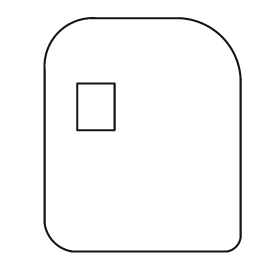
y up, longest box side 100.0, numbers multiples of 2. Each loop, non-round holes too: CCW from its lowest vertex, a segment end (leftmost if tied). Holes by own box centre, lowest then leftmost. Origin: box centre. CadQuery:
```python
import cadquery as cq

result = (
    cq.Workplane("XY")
    .moveTo(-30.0, -50.0)
    .lineTo(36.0, -50.0)
    .threePointArc((40.0, -48.0), (42.0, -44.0))
    .lineTo(42.0, 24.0)
    .threePointArc((34.0, 42.0), (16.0, 50.0))
    .lineTo(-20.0, 50.0)
    .threePointArc((-36.0, 44.0), (-42.0, 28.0))
    .lineTo(-42.0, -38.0)
    .threePointArc((-38.0, -46.0), (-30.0, -50.0))
    .close()
    .moveTo(-28.0, 2.0)
    .lineTo(-12.0, 2.0)
    .lineTo(-12.0, 22.0)
    .lineTo(-28.0, 22.0)
    .close()
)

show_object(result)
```